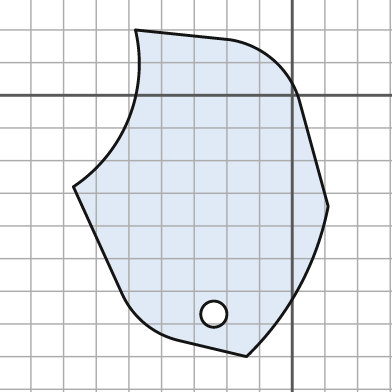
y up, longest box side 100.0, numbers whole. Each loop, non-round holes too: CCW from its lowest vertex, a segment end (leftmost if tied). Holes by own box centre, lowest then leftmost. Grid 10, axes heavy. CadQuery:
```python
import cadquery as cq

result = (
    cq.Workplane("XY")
    .moveTo(-14.0, -80.0)
    .threePointArc((2.0, -59.0), (11.0, -34.0))
    .lineTo(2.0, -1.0)
    .threePointArc((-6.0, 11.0), (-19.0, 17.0))
    .lineTo(-48.0, 20.0)
    .threePointArc((-50.0, -7.0), (-67.0, -28.0))
    .lineTo(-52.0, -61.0)
    .threePointArc((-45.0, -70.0), (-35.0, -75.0))
    .close()
    .moveTo(-24.0, -67.0)
    .circle(4.0)
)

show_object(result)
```